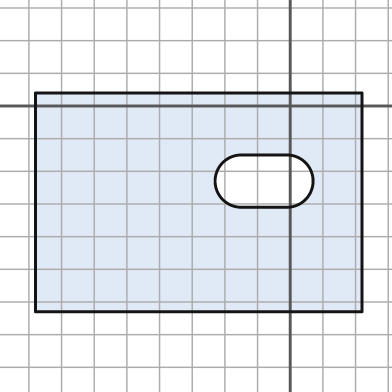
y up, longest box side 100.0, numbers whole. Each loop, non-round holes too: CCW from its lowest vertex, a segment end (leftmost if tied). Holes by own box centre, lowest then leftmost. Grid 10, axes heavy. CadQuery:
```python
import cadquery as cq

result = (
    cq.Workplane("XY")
    .moveTo(-78.0, -63.0)
    .lineTo(22.0, -63.0)
    .lineTo(22.0, 4.0)
    .lineTo(-78.0, 4.0)
    .close()
    .moveTo(-15.0, -31.0)
    .lineTo(-1.0, -31.0)
    .threePointArc((7.0, -23.0), (-1.0, -15.0))
    .lineTo(-15.0, -15.0)
    .threePointArc((-23.0, -23.0), (-15.0, -31.0))
    .close()
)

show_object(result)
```